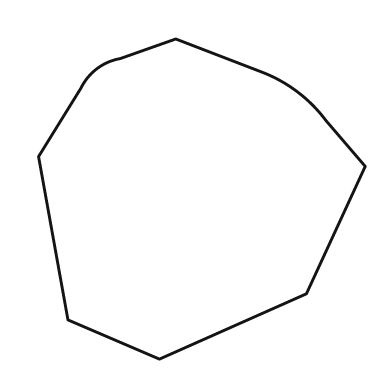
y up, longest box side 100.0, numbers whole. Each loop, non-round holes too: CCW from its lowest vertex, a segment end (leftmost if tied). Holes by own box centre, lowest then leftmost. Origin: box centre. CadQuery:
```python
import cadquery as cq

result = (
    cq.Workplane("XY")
    .moveTo(-13.0, -49.0)
    .lineTo(32.0, -29.0)
    .lineTo(50.0, 10.0)
    .lineTo(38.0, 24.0)
    .threePointArc((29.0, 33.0), (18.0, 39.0))
    .lineTo(-8.0, 49.0)
    .lineTo(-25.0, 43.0)
    .threePointArc((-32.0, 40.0), (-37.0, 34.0))
    .lineTo(-50.0, 13.0)
    .lineTo(-41.0, -37.0)
    .close()
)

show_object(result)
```